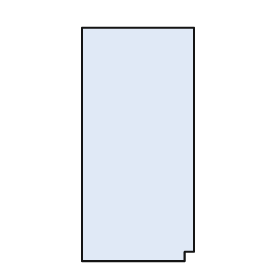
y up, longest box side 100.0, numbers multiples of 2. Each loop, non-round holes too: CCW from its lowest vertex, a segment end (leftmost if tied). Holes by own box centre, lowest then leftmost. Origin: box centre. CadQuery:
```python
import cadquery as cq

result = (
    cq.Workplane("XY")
    .moveTo(-24.0, -50.0)
    .lineTo(20.0, -50.0)
    .lineTo(20.0, -46.0)
    .lineTo(24.0, -46.0)
    .lineTo(24.0, 50.0)
    .lineTo(-24.0, 50.0)
    .close()
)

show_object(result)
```